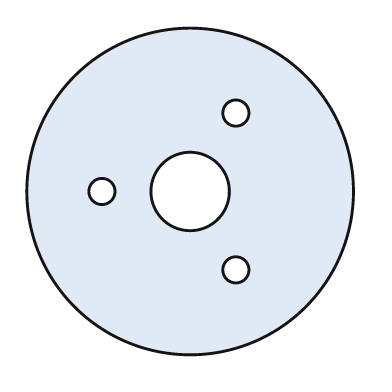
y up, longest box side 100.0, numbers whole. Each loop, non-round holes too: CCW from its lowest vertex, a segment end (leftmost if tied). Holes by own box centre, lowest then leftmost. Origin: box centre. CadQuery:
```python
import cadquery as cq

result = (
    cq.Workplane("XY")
    .moveTo(0.0, 0.0)
    .circle(50.0)
    .moveTo(14.0, -24.0)
    .circle(4.0)
    .moveTo(-27.0, 0.0)
    .circle(4.0)
    .moveTo(0.0, 0.0)
    .circle(12.0)
    .moveTo(14.0, 24.0)
    .circle(4.0)
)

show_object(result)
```